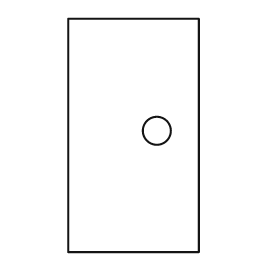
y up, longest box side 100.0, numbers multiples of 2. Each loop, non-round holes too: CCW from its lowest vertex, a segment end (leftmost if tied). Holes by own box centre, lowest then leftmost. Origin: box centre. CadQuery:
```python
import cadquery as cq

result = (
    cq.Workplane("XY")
    .moveTo(-28.0, -50.0)
    .lineTo(28.0, -50.0)
    .lineTo(28.0, 50.0)
    .lineTo(-28.0, 50.0)
    .close()
    .moveTo(10.0, 2.0)
    .circle(6.0)
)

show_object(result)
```